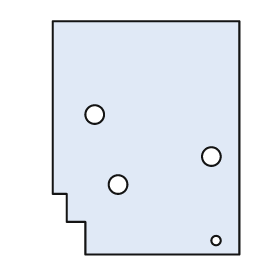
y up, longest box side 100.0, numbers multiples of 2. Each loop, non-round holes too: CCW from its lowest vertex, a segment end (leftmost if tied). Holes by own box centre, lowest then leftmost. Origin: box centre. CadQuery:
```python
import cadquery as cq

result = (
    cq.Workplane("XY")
    .moveTo(-26.0, -50.0)
    .lineTo(40.0, -50.0)
    .lineTo(40.0, 50.0)
    .lineTo(-40.0, 50.0)
    .lineTo(-40.0, -24.0)
    .lineTo(-34.0, -24.0)
    .lineTo(-34.0, -36.0)
    .lineTo(-26.0, -36.0)
    .close()
    .moveTo(30.0, -44.0)
    .circle(2.0)
    .moveTo(-12.0, -20.0)
    .circle(4.0)
    .moveTo(28.0, -8.0)
    .circle(4.0)
    .moveTo(-22.0, 10.0)
    .circle(4.0)
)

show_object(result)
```